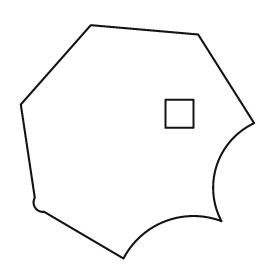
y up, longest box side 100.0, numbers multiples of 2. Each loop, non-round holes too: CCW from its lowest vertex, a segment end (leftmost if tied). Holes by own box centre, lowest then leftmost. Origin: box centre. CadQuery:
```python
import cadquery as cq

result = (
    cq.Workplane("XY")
    .moveTo(-6.0, -50.0)
    .threePointArc((12.0, -34.0), (36.0, -34.0))
    .threePointArc((34.0, -10.0), (50.0, 8.0))
    .lineTo(26.0, 46.0)
    .lineTo(-20.0, 50.0)
    .lineTo(-50.0, 16.0)
    .lineTo(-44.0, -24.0)
    .threePointArc((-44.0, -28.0), (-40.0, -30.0))
    .close()
    .moveTo(12.0, 6.0)
    .lineTo(24.0, 6.0)
    .lineTo(24.0, 18.0)
    .lineTo(12.0, 18.0)
    .close()
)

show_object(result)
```